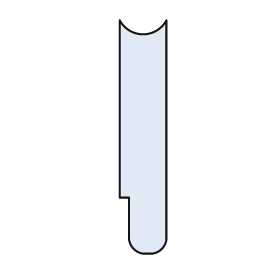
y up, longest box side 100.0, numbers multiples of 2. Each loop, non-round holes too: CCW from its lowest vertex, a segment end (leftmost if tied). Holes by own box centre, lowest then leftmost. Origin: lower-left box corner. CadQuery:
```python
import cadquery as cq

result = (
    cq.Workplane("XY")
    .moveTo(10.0, 0.0)
    .lineTo(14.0, 0.0)
    .threePointArc((18.0, 2.0), (20.0, 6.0))
    .lineTo(20.0, 100.0)
    .threePointArc((10.0, 94.0), (0.0, 100.0))
    .lineTo(0.0, 24.0)
    .lineTo(4.0, 24.0)
    .lineTo(4.0, 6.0)
    .threePointArc((6.0, 2.0), (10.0, 0.0))
    .close()
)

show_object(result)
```